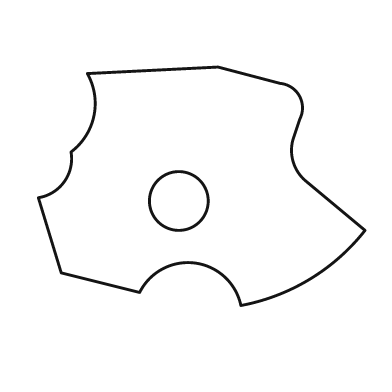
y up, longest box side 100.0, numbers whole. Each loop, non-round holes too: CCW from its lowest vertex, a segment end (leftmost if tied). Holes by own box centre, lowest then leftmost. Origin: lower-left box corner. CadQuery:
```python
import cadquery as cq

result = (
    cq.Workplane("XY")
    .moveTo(62.0, 0.0)
    .threePointArc((83.0, 8.0), (100.0, 23.0))
    .lineTo(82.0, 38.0)
    .threePointArc((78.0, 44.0), (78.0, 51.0))
    .lineTo(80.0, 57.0)
    .threePointArc((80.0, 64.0), (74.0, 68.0))
    .lineTo(55.0, 73.0)
    .lineTo(15.0, 71.0)
    .threePointArc((17.0, 58.0), (10.0, 47.0))
    .threePointArc((8.0, 38.0), (0.0, 33.0))
    .lineTo(7.0, 10.0)
    .lineTo(31.0, 4.0)
    .threePointArc((48.0, 13.0), (62.0, 0.0))
    .close()
    .moveTo(43.0, 32.0)
    .circle(9.0)
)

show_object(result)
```